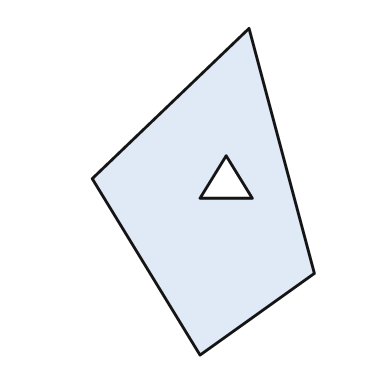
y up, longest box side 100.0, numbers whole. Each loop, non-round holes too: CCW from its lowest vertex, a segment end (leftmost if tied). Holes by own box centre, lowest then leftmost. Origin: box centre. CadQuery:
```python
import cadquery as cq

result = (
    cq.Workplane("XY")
    .moveTo(-1.0, -50.0)
    .lineTo(34.0, -25.0)
    .lineTo(14.0, 50.0)
    .lineTo(-34.0, 4.0)
    .close()
    .moveTo(-1.0, -2.0)
    .lineTo(15.0, -2.0)
    .lineTo(7.0, 11.0)
    .close()
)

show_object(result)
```